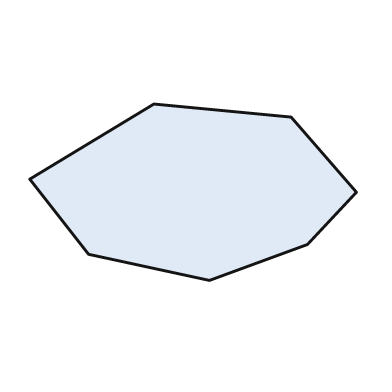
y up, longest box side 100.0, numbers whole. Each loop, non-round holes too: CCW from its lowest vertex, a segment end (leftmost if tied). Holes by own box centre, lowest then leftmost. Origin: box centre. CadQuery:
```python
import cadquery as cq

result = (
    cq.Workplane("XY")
    .moveTo(5.0, -27.0)
    .lineTo(35.0, -16.0)
    .lineTo(50.0, 0.0)
    .lineTo(30.0, 23.0)
    .lineTo(-12.0, 27.0)
    .lineTo(-50.0, 4.0)
    .lineTo(-32.0, -19.0)
    .close()
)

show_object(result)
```